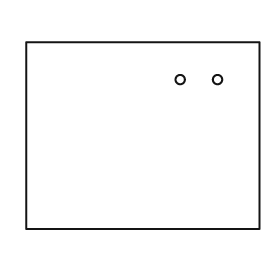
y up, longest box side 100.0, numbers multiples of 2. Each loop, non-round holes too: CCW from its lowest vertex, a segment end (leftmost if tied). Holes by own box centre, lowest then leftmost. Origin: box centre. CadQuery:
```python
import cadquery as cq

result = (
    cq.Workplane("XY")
    .moveTo(-50.0, -40.0)
    .lineTo(50.0, -40.0)
    .lineTo(50.0, 40.0)
    .lineTo(-50.0, 40.0)
    .close()
    .moveTo(16.0, 24.0)
    .circle(2.0)
    .moveTo(32.0, 24.0)
    .circle(2.0)
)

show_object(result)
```